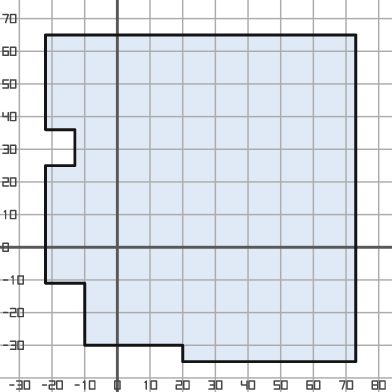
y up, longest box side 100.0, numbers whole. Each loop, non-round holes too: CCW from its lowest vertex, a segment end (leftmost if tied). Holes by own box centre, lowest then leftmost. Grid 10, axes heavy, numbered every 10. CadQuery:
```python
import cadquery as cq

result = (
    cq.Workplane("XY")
    .moveTo(20.0, -35.0)
    .lineTo(73.0, -35.0)
    .lineTo(73.0, 65.0)
    .lineTo(-22.0, 65.0)
    .lineTo(-22.0, 36.0)
    .lineTo(-13.0, 36.0)
    .lineTo(-13.0, 25.0)
    .lineTo(-22.0, 25.0)
    .lineTo(-22.0, -11.0)
    .lineTo(-10.0, -11.0)
    .lineTo(-10.0, -30.0)
    .lineTo(20.0, -30.0)
    .close()
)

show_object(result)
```